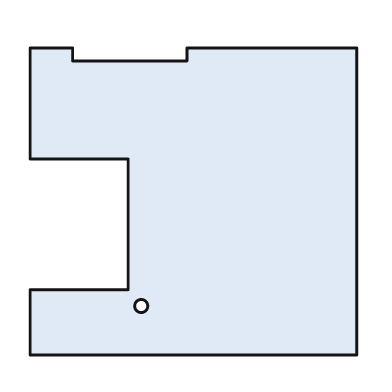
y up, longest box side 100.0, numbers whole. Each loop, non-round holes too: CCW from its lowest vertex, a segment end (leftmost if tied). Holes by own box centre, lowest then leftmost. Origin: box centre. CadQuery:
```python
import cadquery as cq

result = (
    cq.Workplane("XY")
    .moveTo(-50.0, -47.0)
    .lineTo(50.0, -47.0)
    .lineTo(50.0, 47.0)
    .lineTo(-2.0, 47.0)
    .lineTo(-2.0, 43.0)
    .lineTo(-37.0, 43.0)
    .lineTo(-37.0, 47.0)
    .lineTo(-50.0, 47.0)
    .lineTo(-50.0, 13.0)
    .lineTo(-20.0, 13.0)
    .lineTo(-20.0, -27.0)
    .lineTo(-50.0, -27.0)
    .close()
    .moveTo(-16.0, -32.0)
    .circle(2.0)
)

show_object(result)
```